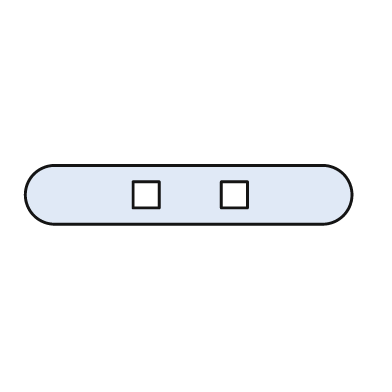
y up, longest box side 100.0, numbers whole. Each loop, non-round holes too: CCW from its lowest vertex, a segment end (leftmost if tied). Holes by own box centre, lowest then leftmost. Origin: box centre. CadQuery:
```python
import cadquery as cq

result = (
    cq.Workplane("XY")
    .moveTo(-41.0, -9.0)
    .lineTo(41.0, -9.0)
    .threePointArc((50.0, 0.0), (41.0, 9.0))
    .lineTo(-41.0, 9.0)
    .threePointArc((-50.0, 0.0), (-41.0, -9.0))
    .close()
    .moveTo(-17.0, -4.0)
    .lineTo(-9.0, -4.0)
    .lineTo(-9.0, 4.0)
    .lineTo(-17.0, 4.0)
    .close()
    .moveTo(10.0, -4.0)
    .lineTo(18.0, -4.0)
    .lineTo(18.0, 4.0)
    .lineTo(10.0, 4.0)
    .close()
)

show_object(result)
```